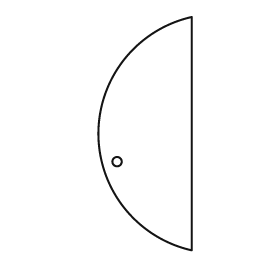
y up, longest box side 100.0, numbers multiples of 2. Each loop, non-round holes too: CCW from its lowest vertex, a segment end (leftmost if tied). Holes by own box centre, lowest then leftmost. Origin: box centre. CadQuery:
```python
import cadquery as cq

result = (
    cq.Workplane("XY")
    .moveTo(20.0, -50.0)
    .lineTo(20.0, 50.0)
    .threePointArc((-20.0, 0.0), (20.0, -50.0))
    .close()
    .moveTo(-12.0, -12.0)
    .circle(2.0)
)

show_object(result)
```